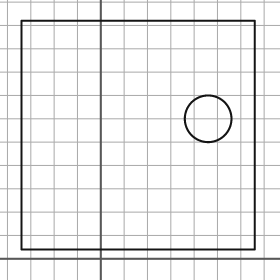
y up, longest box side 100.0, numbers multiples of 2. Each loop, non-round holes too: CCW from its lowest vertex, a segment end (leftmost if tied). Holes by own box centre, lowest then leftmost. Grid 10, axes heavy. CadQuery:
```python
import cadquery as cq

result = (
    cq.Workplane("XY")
    .moveTo(-34.0, 4.0)
    .lineTo(66.0, 4.0)
    .lineTo(66.0, 102.0)
    .lineTo(-34.0, 102.0)
    .close()
    .moveTo(46.0, 60.0)
    .circle(10.0)
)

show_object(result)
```